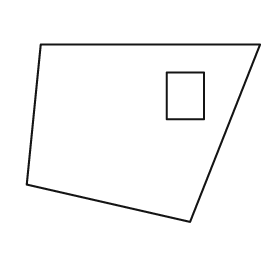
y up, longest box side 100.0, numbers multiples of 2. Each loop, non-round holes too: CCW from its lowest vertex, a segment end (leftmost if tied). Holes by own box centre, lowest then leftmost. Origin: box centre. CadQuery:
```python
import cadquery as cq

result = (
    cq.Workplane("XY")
    .moveTo(20.0, -38.0)
    .lineTo(50.0, 38.0)
    .lineTo(-44.0, 38.0)
    .lineTo(-50.0, -22.0)
    .close()
    .moveTo(10.0, 6.0)
    .lineTo(26.0, 6.0)
    .lineTo(26.0, 26.0)
    .lineTo(10.0, 26.0)
    .close()
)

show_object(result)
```